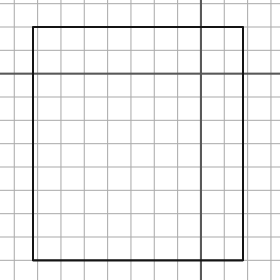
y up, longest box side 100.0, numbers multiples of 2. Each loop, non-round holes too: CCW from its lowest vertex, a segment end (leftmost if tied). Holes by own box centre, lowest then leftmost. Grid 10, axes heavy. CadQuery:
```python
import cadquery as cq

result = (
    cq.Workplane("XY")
    .moveTo(-72.0, -80.0)
    .lineTo(18.0, -80.0)
    .lineTo(18.0, 20.0)
    .lineTo(-72.0, 20.0)
    .close()
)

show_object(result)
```